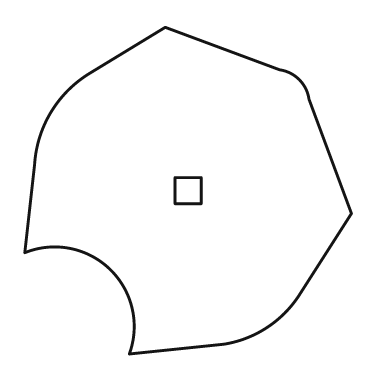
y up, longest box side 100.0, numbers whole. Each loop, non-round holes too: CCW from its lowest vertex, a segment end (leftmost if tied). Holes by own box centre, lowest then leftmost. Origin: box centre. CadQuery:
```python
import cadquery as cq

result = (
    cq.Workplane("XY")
    .moveTo(-18.0, -50.0)
    .lineTo(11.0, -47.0)
    .threePointArc((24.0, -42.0), (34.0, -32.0))
    .lineTo(50.0, -7.0)
    .lineTo(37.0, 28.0)
    .threePointArc((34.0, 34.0), (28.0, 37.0))
    .lineTo(-7.0, 50.0)
    .lineTo(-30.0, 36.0)
    .threePointArc((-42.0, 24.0), (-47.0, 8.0))
    .lineTo(-50.0, -19.0)
    .threePointArc((-24.0, -24.0), (-18.0, -50.0))
    .close()
    .moveTo(-4.0, -4.0)
    .lineTo(4.0, -4.0)
    .lineTo(4.0, 4.0)
    .lineTo(-4.0, 4.0)
    .close()
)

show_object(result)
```